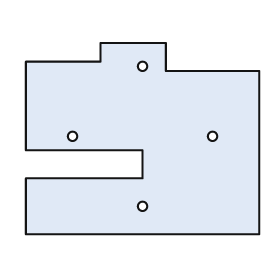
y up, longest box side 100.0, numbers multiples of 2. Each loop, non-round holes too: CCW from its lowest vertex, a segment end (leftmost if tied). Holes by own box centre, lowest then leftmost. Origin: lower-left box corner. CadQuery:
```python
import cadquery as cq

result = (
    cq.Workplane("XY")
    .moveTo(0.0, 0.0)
    .lineTo(100.0, 0.0)
    .lineTo(100.0, 70.0)
    .lineTo(60.0, 70.0)
    .lineTo(60.0, 82.0)
    .lineTo(32.0, 82.0)
    .lineTo(32.0, 74.0)
    .lineTo(0.0, 74.0)
    .lineTo(0.0, 36.0)
    .lineTo(50.0, 36.0)
    .lineTo(50.0, 24.0)
    .lineTo(0.0, 24.0)
    .close()
    .moveTo(50.0, 12.0)
    .circle(2.0)
    .moveTo(20.0, 42.0)
    .circle(2.0)
    .moveTo(80.0, 42.0)
    .circle(2.0)
    .moveTo(50.0, 72.0)
    .circle(2.0)
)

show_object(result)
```